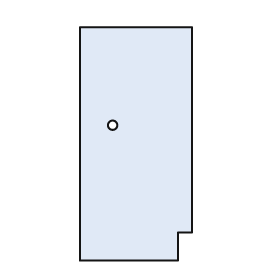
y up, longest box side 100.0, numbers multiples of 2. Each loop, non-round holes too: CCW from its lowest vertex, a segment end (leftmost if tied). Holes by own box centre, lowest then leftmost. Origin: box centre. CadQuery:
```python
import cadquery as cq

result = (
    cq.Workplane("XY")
    .moveTo(-24.0, -50.0)
    .lineTo(18.0, -50.0)
    .lineTo(18.0, -38.0)
    .lineTo(24.0, -38.0)
    .lineTo(24.0, 50.0)
    .lineTo(-24.0, 50.0)
    .close()
    .moveTo(-10.0, 8.0)
    .circle(2.0)
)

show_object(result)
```